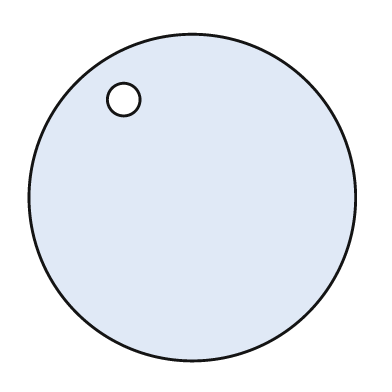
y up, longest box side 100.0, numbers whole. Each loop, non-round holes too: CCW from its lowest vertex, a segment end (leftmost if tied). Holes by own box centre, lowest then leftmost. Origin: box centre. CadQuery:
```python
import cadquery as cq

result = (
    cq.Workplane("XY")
    .moveTo(0.0, 0.0)
    .circle(50.0)
    .moveTo(-21.0, 30.0)
    .circle(5.0)
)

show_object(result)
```